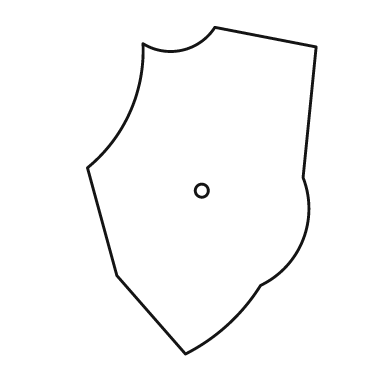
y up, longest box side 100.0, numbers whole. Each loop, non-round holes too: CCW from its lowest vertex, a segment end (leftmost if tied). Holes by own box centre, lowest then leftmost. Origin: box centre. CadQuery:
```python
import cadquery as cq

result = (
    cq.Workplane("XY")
    .moveTo(-5.0, -50.0)
    .threePointArc((8.0, -41.0), (18.0, -29.0))
    .threePointArc((31.0, -15.0), (31.0, 4.0))
    .lineTo(35.0, 44.0)
    .lineTo(4.0, 50.0)
    .threePointArc((-6.0, 43.0), (-18.0, 45.0))
    .threePointArc((-22.0, 24.0), (-35.0, 7.0))
    .lineTo(-26.0, -26.0)
    .close()
    .moveTo(0.0, 0.0)
    .circle(2.0)
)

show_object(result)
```